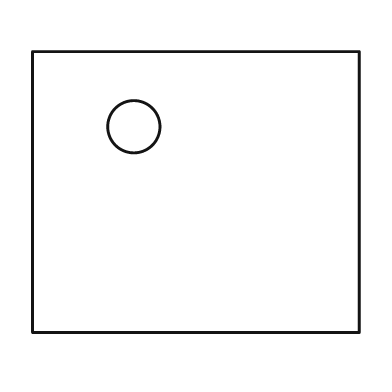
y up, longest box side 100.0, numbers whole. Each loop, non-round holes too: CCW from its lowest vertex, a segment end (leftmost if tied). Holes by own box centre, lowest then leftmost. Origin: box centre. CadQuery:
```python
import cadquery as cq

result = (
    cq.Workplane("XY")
    .moveTo(-50.0, -43.0)
    .lineTo(50.0, -43.0)
    .lineTo(50.0, 43.0)
    .lineTo(-50.0, 43.0)
    .close()
    .moveTo(-19.0, 20.0)
    .circle(8.0)
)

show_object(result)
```